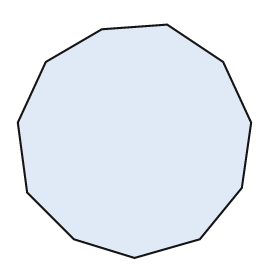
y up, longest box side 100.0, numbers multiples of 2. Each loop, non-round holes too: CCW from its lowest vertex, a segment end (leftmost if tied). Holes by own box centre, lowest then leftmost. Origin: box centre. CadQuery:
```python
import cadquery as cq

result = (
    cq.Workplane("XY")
    .moveTo(0.0, -50.0)
    .lineTo(28.0, -42.0)
    .lineTo(46.0, -20.0)
    .lineTo(50.0, 8.0)
    .lineTo(38.0, 34.0)
    .lineTo(14.0, 50.0)
    .lineTo(-14.0, 48.0)
    .lineTo(-38.0, 34.0)
    .lineTo(-50.0, 8.0)
    .lineTo(-46.0, -22.0)
    .lineTo(-26.0, -42.0)
    .close()
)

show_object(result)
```